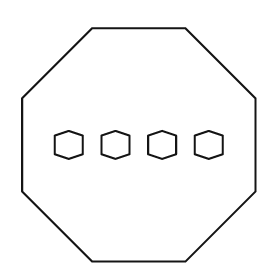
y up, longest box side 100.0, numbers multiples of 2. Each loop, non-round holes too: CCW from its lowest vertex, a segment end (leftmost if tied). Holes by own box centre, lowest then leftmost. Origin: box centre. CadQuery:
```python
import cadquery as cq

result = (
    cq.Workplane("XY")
    .moveTo(-20.0, -50.0)
    .lineTo(20.0, -50.0)
    .lineTo(50.0, -20.0)
    .lineTo(50.0, 20.0)
    .lineTo(20.0, 50.0)
    .lineTo(-20.0, 50.0)
    .lineTo(-50.0, 20.0)
    .lineTo(-50.0, -20.0)
    .close()
    .moveTo(-30.0, -6.0)
    .lineTo(-24.0, -4.0)
    .lineTo(-24.0, 4.0)
    .lineTo(-30.0, 6.0)
    .lineTo(-36.0, 4.0)
    .lineTo(-36.0, -4.0)
    .close()
    .moveTo(-10.0, -6.0)
    .lineTo(-4.0, -4.0)
    .lineTo(-4.0, 4.0)
    .lineTo(-10.0, 6.0)
    .lineTo(-16.0, 4.0)
    .lineTo(-16.0, -4.0)
    .close()
    .moveTo(10.0, -6.0)
    .lineTo(16.0, -4.0)
    .lineTo(16.0, 4.0)
    .lineTo(10.0, 6.0)
    .lineTo(4.0, 4.0)
    .lineTo(4.0, -4.0)
    .close()
    .moveTo(30.0, -6.0)
    .lineTo(36.0, -4.0)
    .lineTo(36.0, 4.0)
    .lineTo(30.0, 6.0)
    .lineTo(24.0, 4.0)
    .lineTo(24.0, -4.0)
    .close()
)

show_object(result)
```